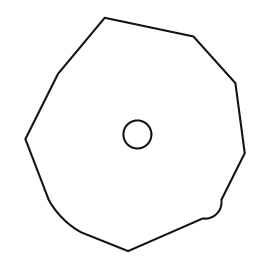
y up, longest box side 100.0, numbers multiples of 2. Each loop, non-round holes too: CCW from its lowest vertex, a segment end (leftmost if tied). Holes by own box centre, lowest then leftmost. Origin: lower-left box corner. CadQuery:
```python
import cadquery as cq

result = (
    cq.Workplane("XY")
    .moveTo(44.0, 0.0)
    .lineTo(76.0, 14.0)
    .threePointArc((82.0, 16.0), (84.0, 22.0))
    .lineTo(94.0, 42.0)
    .lineTo(90.0, 72.0)
    .lineTo(72.0, 92.0)
    .lineTo(34.0, 100.0)
    .lineTo(14.0, 76.0)
    .lineTo(0.0, 48.0)
    .lineTo(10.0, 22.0)
    .threePointArc((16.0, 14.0), (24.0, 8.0))
    .close()
    .moveTo(48.0, 50.0)
    .circle(6.0)
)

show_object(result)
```